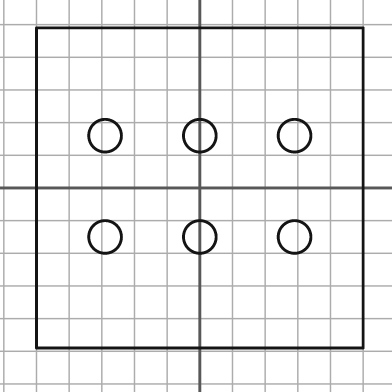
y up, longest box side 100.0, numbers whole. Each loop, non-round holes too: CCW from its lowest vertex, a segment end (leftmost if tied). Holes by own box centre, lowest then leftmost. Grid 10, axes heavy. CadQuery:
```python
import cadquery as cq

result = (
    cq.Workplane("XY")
    .moveTo(-50.0, -49.0)
    .lineTo(50.0, -49.0)
    .lineTo(50.0, 49.0)
    .lineTo(-50.0, 49.0)
    .close()
    .moveTo(-29.0, -15.0)
    .circle(5.0)
    .moveTo(0.0, -15.0)
    .circle(5.0)
    .moveTo(29.0, -15.0)
    .circle(5.0)
    .moveTo(-29.0, 16.0)
    .circle(5.0)
    .moveTo(0.0, 16.0)
    .circle(5.0)
    .moveTo(29.0, 16.0)
    .circle(5.0)
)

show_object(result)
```